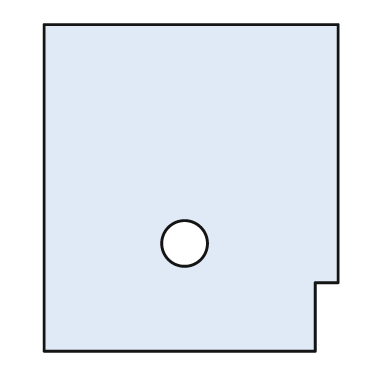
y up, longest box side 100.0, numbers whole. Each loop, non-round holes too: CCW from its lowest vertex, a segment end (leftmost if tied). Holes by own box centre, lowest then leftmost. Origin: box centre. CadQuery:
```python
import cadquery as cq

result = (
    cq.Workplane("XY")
    .moveTo(-45.0, -50.0)
    .lineTo(38.0, -50.0)
    .lineTo(38.0, -29.0)
    .lineTo(45.0, -29.0)
    .lineTo(45.0, 50.0)
    .lineTo(-45.0, 50.0)
    .close()
    .moveTo(-2.0, -17.0)
    .circle(7.0)
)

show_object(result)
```